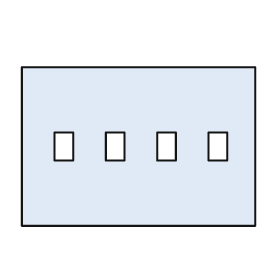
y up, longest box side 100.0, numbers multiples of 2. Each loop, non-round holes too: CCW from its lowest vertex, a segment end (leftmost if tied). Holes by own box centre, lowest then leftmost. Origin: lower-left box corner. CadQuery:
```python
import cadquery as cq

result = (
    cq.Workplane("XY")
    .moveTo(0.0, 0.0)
    .lineTo(100.0, 0.0)
    .lineTo(100.0, 68.0)
    .lineTo(0.0, 68.0)
    .close()
    .moveTo(14.0, 28.0)
    .lineTo(22.0, 28.0)
    .lineTo(22.0, 40.0)
    .lineTo(14.0, 40.0)
    .close()
    .moveTo(36.0, 28.0)
    .lineTo(44.0, 28.0)
    .lineTo(44.0, 40.0)
    .lineTo(36.0, 40.0)
    .close()
    .moveTo(58.0, 28.0)
    .lineTo(66.0, 28.0)
    .lineTo(66.0, 40.0)
    .lineTo(58.0, 40.0)
    .close()
    .moveTo(80.0, 28.0)
    .lineTo(88.0, 28.0)
    .lineTo(88.0, 40.0)
    .lineTo(80.0, 40.0)
    .close()
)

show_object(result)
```